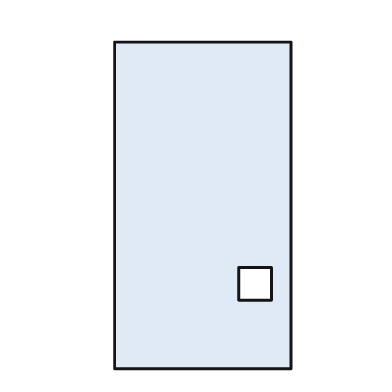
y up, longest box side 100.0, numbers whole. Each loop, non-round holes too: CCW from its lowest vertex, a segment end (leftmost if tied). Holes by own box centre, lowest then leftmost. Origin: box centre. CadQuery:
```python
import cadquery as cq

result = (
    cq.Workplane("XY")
    .moveTo(-27.0, -50.0)
    .lineTo(27.0, -50.0)
    .lineTo(27.0, 50.0)
    .lineTo(-27.0, 50.0)
    .close()
    .moveTo(11.0, -29.0)
    .lineTo(21.0, -29.0)
    .lineTo(21.0, -19.0)
    .lineTo(11.0, -19.0)
    .close()
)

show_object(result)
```